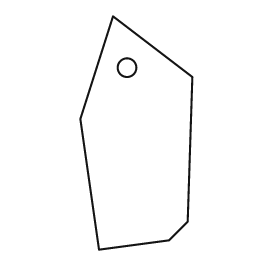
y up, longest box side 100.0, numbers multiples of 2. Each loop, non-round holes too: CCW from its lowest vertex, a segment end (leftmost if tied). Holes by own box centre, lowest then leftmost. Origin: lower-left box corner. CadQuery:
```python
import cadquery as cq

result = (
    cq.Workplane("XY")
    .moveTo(8.0, 0.0)
    .lineTo(38.0, 4.0)
    .lineTo(46.0, 12.0)
    .lineTo(48.0, 74.0)
    .lineTo(14.0, 100.0)
    .lineTo(0.0, 56.0)
    .close()
    .moveTo(20.0, 78.0)
    .circle(4.0)
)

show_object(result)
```